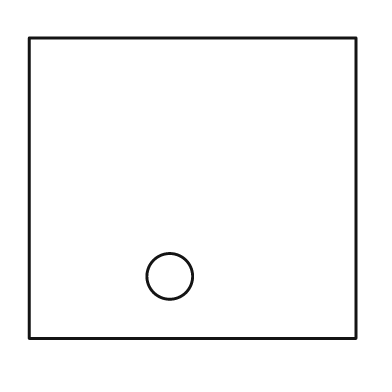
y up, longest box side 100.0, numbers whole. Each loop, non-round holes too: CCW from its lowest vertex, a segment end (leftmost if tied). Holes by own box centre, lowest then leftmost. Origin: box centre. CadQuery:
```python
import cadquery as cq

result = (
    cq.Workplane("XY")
    .moveTo(-50.0, -46.0)
    .lineTo(50.0, -46.0)
    .lineTo(50.0, 46.0)
    .lineTo(-50.0, 46.0)
    .close()
    .moveTo(-7.0, -27.0)
    .circle(7.0)
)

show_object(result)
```